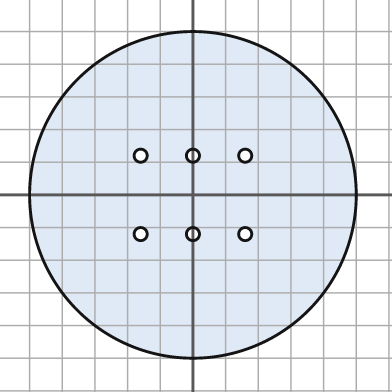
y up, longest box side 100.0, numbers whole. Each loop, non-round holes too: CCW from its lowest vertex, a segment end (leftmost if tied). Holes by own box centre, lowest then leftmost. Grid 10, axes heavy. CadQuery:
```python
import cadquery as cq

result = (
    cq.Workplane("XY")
    .moveTo(0.0, 0.0)
    .circle(50.0)
    .moveTo(-16.0, -12.0)
    .circle(2.0)
    .moveTo(0.0, -12.0)
    .circle(2.0)
    .moveTo(16.0, -12.0)
    .circle(2.0)
    .moveTo(-16.0, 12.0)
    .circle(2.0)
    .moveTo(0.0, 12.0)
    .circle(2.0)
    .moveTo(16.0, 12.0)
    .circle(2.0)
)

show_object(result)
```